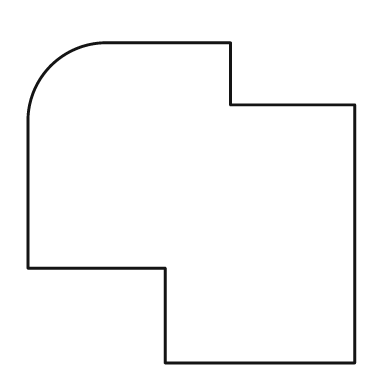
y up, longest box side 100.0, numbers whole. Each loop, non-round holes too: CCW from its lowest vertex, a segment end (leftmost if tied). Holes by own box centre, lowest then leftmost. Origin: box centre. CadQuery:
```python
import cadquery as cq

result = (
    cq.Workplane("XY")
    .moveTo(-8.0, -49.0)
    .lineTo(50.0, -49.0)
    .lineTo(50.0, 30.0)
    .lineTo(12.0, 30.0)
    .lineTo(12.0, 49.0)
    .lineTo(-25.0, 49.0)
    .threePointArc((-43.0, 42.0), (-50.0, 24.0))
    .lineTo(-50.0, -20.0)
    .lineTo(-8.0, -20.0)
    .close()
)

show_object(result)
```